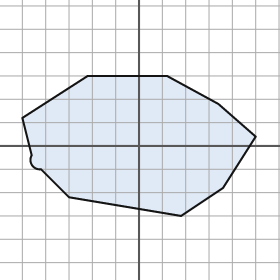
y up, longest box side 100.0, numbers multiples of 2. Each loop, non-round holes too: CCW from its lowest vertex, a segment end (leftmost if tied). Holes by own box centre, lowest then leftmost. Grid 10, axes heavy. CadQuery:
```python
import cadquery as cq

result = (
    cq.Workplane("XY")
    .moveTo(18.0, -30.0)
    .lineTo(36.0, -18.0)
    .lineTo(50.0, 4.0)
    .lineTo(34.0, 18.0)
    .lineTo(12.0, 30.0)
    .lineTo(-22.0, 30.0)
    .lineTo(-50.0, 12.0)
    .lineTo(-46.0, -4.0)
    .threePointArc((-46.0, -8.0), (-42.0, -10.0))
    .lineTo(-30.0, -22.0)
    .close()
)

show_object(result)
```